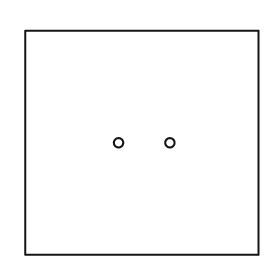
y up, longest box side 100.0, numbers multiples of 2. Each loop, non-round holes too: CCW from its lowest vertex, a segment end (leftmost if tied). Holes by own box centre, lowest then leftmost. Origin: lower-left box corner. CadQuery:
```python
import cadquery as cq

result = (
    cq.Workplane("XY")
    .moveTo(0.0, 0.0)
    .lineTo(100.0, 0.0)
    .lineTo(100.0, 96.0)
    .lineTo(0.0, 96.0)
    .close()
    .moveTo(40.0, 48.0)
    .circle(2.0)
    .moveTo(62.0, 48.0)
    .circle(2.0)
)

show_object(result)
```